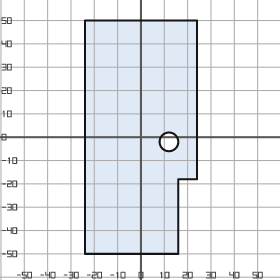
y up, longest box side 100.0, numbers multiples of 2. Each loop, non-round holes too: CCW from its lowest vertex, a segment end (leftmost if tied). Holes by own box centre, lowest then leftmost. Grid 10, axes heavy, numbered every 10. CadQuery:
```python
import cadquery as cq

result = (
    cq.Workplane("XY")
    .moveTo(-24.0, -50.0)
    .lineTo(16.0, -50.0)
    .lineTo(16.0, -18.0)
    .lineTo(24.0, -18.0)
    .lineTo(24.0, 50.0)
    .lineTo(-24.0, 50.0)
    .close()
    .moveTo(12.0, -2.0)
    .circle(4.0)
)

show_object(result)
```